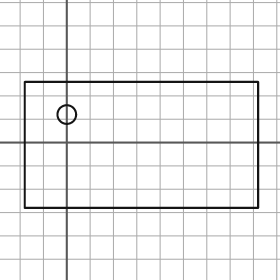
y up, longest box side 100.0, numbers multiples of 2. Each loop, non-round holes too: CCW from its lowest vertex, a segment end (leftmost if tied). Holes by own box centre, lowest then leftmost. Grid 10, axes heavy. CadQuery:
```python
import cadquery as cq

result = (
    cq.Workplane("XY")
    .moveTo(-18.0, -28.0)
    .lineTo(82.0, -28.0)
    .lineTo(82.0, 26.0)
    .lineTo(-18.0, 26.0)
    .close()
    .moveTo(0.0, 12.0)
    .circle(4.0)
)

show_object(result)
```